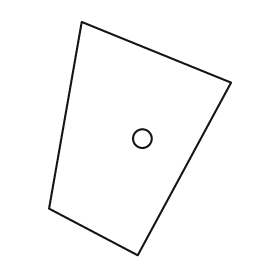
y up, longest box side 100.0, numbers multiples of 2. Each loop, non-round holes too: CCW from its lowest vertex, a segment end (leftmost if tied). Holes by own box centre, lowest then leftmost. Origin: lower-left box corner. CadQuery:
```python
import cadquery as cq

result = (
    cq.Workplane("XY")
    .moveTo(38.0, 0.0)
    .lineTo(78.0, 74.0)
    .lineTo(14.0, 100.0)
    .lineTo(0.0, 20.0)
    .close()
    .moveTo(40.0, 50.0)
    .circle(4.0)
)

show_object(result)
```